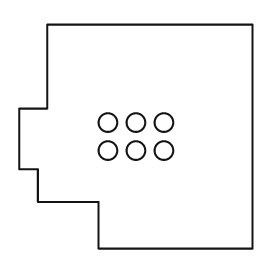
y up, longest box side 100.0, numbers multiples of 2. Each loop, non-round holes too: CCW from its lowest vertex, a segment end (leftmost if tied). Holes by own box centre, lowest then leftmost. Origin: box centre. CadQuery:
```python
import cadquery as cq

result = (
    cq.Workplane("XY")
    .moveTo(-16.0, -48.0)
    .lineTo(50.0, -48.0)
    .lineTo(50.0, 48.0)
    .lineTo(-38.0, 48.0)
    .lineTo(-38.0, 12.0)
    .lineTo(-50.0, 12.0)
    .lineTo(-50.0, -14.0)
    .lineTo(-42.0, -14.0)
    .lineTo(-42.0, -28.0)
    .lineTo(-16.0, -28.0)
    .close()
    .moveTo(-12.0, -6.0)
    .circle(4.0)
    .moveTo(0.0, -6.0)
    .circle(4.0)
    .moveTo(12.0, -6.0)
    .circle(4.0)
    .moveTo(-12.0, 6.0)
    .circle(4.0)
    .moveTo(0.0, 6.0)
    .circle(4.0)
    .moveTo(12.0, 6.0)
    .circle(4.0)
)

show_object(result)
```